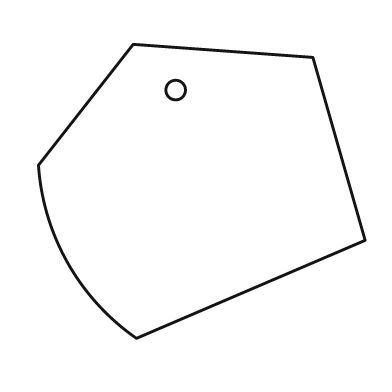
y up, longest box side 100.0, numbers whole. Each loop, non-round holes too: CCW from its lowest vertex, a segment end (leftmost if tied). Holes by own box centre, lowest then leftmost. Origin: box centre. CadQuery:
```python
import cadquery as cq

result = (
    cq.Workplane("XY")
    .moveTo(-20.0, -45.0)
    .lineTo(50.0, -15.0)
    .lineTo(34.0, 41.0)
    .lineTo(-21.0, 45.0)
    .lineTo(-50.0, 8.0)
    .threePointArc((-41.0, -22.0), (-20.0, -45.0))
    .close()
    .moveTo(-8.0, 31.0)
    .circle(3.0)
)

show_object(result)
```